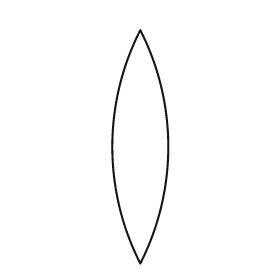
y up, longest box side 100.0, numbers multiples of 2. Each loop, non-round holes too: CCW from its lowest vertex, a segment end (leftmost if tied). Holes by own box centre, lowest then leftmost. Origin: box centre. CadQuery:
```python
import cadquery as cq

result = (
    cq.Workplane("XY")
    .moveTo(0.0, -50.0)
    .threePointArc((12.0, 0.0), (0.0, 50.0))
    .threePointArc((-12.0, 0.0), (0.0, -50.0))
    .close()
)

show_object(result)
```